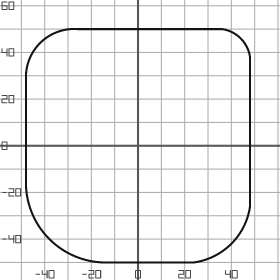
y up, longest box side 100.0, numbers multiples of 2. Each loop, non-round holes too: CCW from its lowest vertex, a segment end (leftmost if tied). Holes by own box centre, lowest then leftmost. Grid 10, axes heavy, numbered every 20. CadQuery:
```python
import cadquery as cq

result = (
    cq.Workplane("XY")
    .moveTo(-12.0, -50.0)
    .lineTo(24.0, -50.0)
    .threePointArc((40.0, -42.0), (48.0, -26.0))
    .lineTo(48.0, 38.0)
    .threePointArc((44.0, 46.0), (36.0, 50.0))
    .lineTo(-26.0, 50.0)
    .threePointArc((-42.0, 44.0), (-48.0, 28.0))
    .lineTo(-48.0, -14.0)
    .threePointArc((-38.0, -40.0), (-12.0, -50.0))
    .close()
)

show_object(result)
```